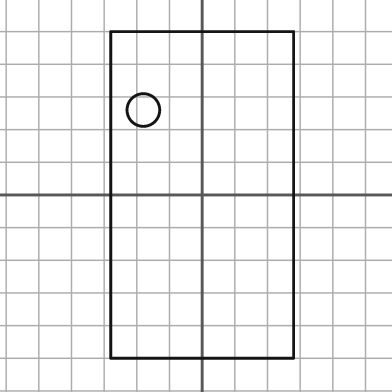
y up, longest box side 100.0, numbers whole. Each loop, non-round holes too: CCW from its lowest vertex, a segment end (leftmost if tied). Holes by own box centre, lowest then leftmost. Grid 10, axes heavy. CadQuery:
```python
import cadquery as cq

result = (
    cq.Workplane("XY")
    .moveTo(-28.0, -50.0)
    .lineTo(28.0, -50.0)
    .lineTo(28.0, 50.0)
    .lineTo(-28.0, 50.0)
    .close()
    .moveTo(-18.0, 26.0)
    .circle(5.0)
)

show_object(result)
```